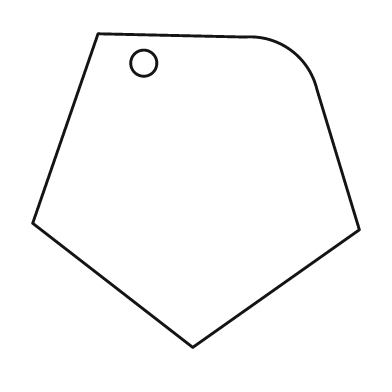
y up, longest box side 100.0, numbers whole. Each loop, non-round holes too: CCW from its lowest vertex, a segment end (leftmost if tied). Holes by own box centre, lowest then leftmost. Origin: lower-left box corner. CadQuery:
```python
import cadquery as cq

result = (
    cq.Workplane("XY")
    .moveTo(49.0, 0.0)
    .lineTo(100.0, 36.0)
    .lineTo(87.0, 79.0)
    .threePointArc((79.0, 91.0), (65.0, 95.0))
    .lineTo(20.0, 96.0)
    .lineTo(0.0, 38.0)
    .close()
    .moveTo(34.0, 87.0)
    .circle(4.0)
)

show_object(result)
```